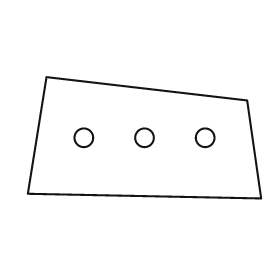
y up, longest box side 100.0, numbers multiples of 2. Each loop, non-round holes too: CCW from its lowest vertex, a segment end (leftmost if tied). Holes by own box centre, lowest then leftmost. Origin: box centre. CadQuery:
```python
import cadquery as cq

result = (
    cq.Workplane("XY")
    .moveTo(50.0, -26.0)
    .lineTo(44.0, 16.0)
    .lineTo(-42.0, 26.0)
    .lineTo(-50.0, -24.0)
    .close()
    .moveTo(-26.0, 0.0)
    .circle(4.0)
    .moveTo(0.0, 0.0)
    .circle(4.0)
    .moveTo(26.0, 0.0)
    .circle(4.0)
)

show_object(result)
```